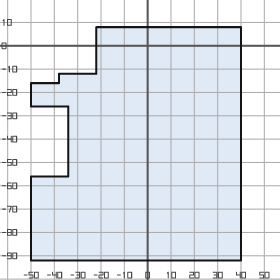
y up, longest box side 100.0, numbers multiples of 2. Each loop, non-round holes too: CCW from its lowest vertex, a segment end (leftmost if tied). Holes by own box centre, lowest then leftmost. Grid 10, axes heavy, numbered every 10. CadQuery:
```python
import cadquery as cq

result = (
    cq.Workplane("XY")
    .moveTo(-50.0, -92.0)
    .lineTo(40.0, -92.0)
    .lineTo(40.0, 8.0)
    .lineTo(-22.0, 8.0)
    .lineTo(-22.0, -12.0)
    .lineTo(-38.0, -12.0)
    .lineTo(-38.0, -16.0)
    .lineTo(-50.0, -16.0)
    .lineTo(-50.0, -26.0)
    .lineTo(-34.0, -26.0)
    .lineTo(-34.0, -56.0)
    .lineTo(-50.0, -56.0)
    .close()
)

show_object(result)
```